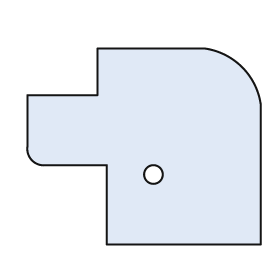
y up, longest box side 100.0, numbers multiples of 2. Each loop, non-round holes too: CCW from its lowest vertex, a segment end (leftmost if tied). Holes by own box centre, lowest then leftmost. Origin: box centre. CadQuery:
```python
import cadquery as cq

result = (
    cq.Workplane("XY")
    .moveTo(-16.0, -42.0)
    .lineTo(50.0, -42.0)
    .lineTo(50.0, 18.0)
    .threePointArc((42.0, 34.0), (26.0, 42.0))
    .lineTo(-20.0, 42.0)
    .lineTo(-20.0, 22.0)
    .lineTo(-50.0, 22.0)
    .lineTo(-50.0, 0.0)
    .threePointArc((-48.0, -6.0), (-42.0, -8.0))
    .lineTo(-16.0, -8.0)
    .close()
    .moveTo(4.0, -12.0)
    .circle(4.0)
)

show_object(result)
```